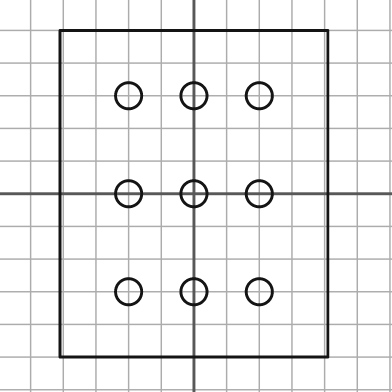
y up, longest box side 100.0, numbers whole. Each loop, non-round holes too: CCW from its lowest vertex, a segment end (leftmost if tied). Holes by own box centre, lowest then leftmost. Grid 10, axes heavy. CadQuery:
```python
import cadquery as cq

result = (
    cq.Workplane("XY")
    .moveTo(-41.0, -50.0)
    .lineTo(41.0, -50.0)
    .lineTo(41.0, 50.0)
    .lineTo(-41.0, 50.0)
    .close()
    .moveTo(-20.0, -30.0)
    .circle(4.0)
    .moveTo(0.0, -30.0)
    .circle(4.0)
    .moveTo(20.0, -30.0)
    .circle(4.0)
    .moveTo(-20.0, 0.0)
    .circle(4.0)
    .moveTo(0.0, 0.0)
    .circle(4.0)
    .moveTo(20.0, 0.0)
    .circle(4.0)
    .moveTo(-20.0, 30.0)
    .circle(4.0)
    .moveTo(0.0, 30.0)
    .circle(4.0)
    .moveTo(20.0, 30.0)
    .circle(4.0)
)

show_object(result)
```